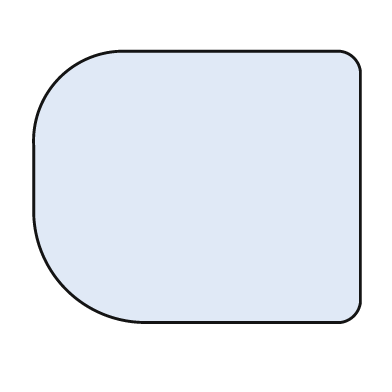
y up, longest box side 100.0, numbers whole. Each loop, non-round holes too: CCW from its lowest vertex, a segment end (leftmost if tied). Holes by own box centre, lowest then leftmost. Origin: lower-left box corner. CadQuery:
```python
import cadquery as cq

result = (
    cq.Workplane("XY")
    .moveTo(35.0, 0.0)
    .lineTo(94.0, 0.0)
    .threePointArc((98.0, 2.0), (100.0, 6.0))
    .lineTo(100.0, 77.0)
    .threePointArc((98.0, 81.0), (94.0, 83.0))
    .lineTo(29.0, 83.0)
    .threePointArc((8.0, 75.0), (0.0, 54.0))
    .lineTo(0.0, 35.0)
    .threePointArc((10.0, 10.0), (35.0, 0.0))
    .close()
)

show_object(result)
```